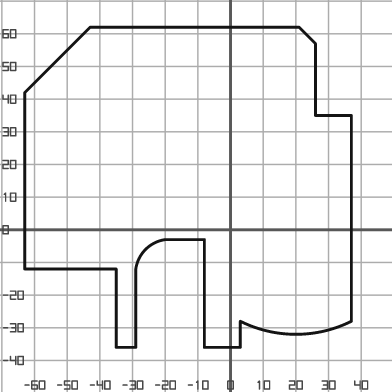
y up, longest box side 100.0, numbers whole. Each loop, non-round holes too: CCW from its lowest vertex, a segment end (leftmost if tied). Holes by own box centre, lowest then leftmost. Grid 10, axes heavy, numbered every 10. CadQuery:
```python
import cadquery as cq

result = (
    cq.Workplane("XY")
    .moveTo(-35.0, -36.0)
    .lineTo(-29.0, -36.0)
    .lineTo(-29.0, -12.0)
    .threePointArc((-26.0, -6.0), (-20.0, -3.0))
    .lineTo(-8.0, -3.0)
    .lineTo(-8.0, -36.0)
    .lineTo(3.0, -36.0)
    .lineTo(3.0, -28.0)
    .threePointArc((20.0, -32.0), (37.0, -28.0))
    .lineTo(37.0, 35.0)
    .lineTo(26.0, 35.0)
    .lineTo(26.0, 57.0)
    .lineTo(21.0, 62.0)
    .lineTo(-43.0, 62.0)
    .lineTo(-63.0, 42.0)
    .lineTo(-63.0, -12.0)
    .lineTo(-35.0, -12.0)
    .close()
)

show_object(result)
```